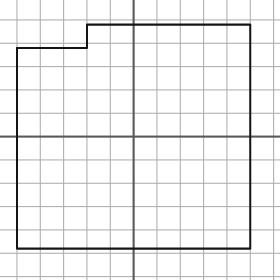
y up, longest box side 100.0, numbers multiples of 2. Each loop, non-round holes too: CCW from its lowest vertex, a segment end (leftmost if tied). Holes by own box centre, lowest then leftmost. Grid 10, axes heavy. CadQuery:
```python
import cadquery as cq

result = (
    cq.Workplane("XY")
    .moveTo(-50.0, -48.0)
    .lineTo(50.0, -48.0)
    .lineTo(50.0, 48.0)
    .lineTo(-20.0, 48.0)
    .lineTo(-20.0, 38.0)
    .lineTo(-50.0, 38.0)
    .close()
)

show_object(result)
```